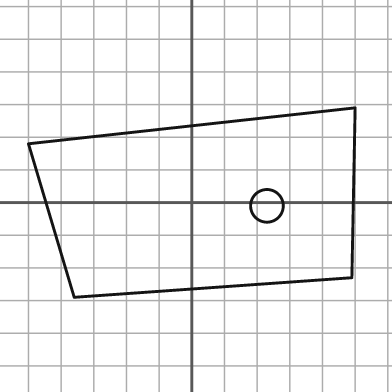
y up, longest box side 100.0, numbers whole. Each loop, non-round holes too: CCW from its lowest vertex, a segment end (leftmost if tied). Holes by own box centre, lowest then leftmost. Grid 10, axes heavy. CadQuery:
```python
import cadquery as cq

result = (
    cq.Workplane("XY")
    .moveTo(-36.0, -29.0)
    .lineTo(49.0, -23.0)
    .lineTo(50.0, 29.0)
    .lineTo(-50.0, 18.0)
    .close()
    .moveTo(23.0, -1.0)
    .circle(5.0)
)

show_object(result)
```